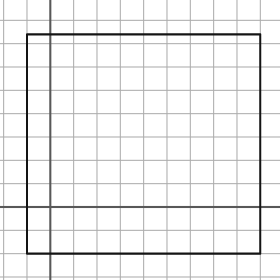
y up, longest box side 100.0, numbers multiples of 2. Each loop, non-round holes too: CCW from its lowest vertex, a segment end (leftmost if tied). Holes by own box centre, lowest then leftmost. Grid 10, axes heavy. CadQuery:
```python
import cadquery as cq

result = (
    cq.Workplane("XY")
    .moveTo(-10.0, -20.0)
    .lineTo(90.0, -20.0)
    .lineTo(90.0, 74.0)
    .lineTo(-10.0, 74.0)
    .close()
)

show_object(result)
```